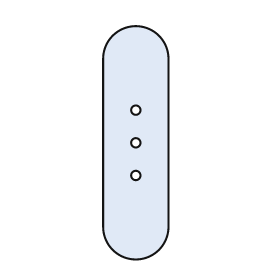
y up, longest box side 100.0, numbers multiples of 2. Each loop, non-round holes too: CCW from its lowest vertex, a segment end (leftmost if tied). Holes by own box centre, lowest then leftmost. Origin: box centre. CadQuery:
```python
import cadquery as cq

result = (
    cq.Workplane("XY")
    .moveTo(-14.0, -36.0)
    .threePointArc((0.0, -50.0), (14.0, -36.0))
    .lineTo(14.0, 36.0)
    .threePointArc((0.0, 50.0), (-14.0, 36.0))
    .close()
    .moveTo(0.0, -14.0)
    .circle(2.0)
    .moveTo(0.0, 0.0)
    .circle(2.0)
    .moveTo(0.0, 14.0)
    .circle(2.0)
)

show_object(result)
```